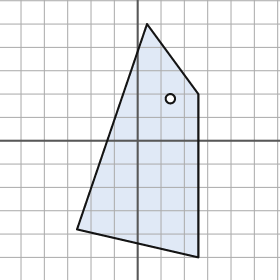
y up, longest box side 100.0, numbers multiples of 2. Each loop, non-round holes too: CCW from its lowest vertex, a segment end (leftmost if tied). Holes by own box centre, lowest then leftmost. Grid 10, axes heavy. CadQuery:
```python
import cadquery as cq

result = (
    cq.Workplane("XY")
    .moveTo(26.0, -50.0)
    .lineTo(26.0, 20.0)
    .lineTo(4.0, 50.0)
    .lineTo(-26.0, -38.0)
    .close()
    .moveTo(14.0, 18.0)
    .circle(2.0)
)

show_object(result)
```